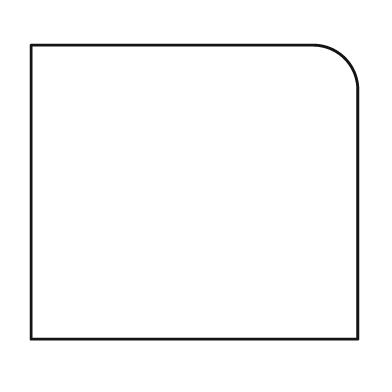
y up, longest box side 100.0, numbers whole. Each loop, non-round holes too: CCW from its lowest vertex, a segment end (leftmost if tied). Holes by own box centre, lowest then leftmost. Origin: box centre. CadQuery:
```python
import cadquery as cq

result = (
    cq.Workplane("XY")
    .moveTo(-50.0, -45.0)
    .lineTo(50.0, -45.0)
    .lineTo(50.0, 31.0)
    .threePointArc((46.0, 41.0), (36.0, 45.0))
    .lineTo(-50.0, 45.0)
    .close()
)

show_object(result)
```